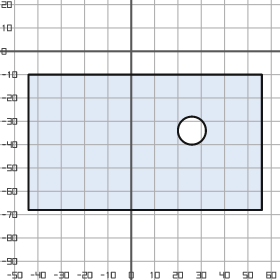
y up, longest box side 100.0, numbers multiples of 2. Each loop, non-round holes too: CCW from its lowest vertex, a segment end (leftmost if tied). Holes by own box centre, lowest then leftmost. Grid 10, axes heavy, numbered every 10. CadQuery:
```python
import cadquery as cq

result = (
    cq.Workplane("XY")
    .moveTo(-44.0, -68.0)
    .lineTo(56.0, -68.0)
    .lineTo(56.0, -10.0)
    .lineTo(-44.0, -10.0)
    .close()
    .moveTo(26.0, -34.0)
    .circle(6.0)
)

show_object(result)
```